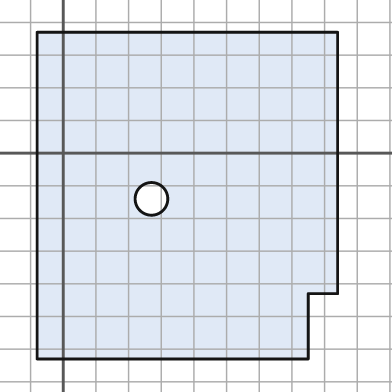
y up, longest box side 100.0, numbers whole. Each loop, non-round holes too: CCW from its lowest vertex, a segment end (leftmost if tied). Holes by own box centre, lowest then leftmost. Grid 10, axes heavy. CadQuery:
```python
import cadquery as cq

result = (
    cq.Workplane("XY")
    .moveTo(-8.0, -63.0)
    .lineTo(75.0, -63.0)
    .lineTo(75.0, -43.0)
    .lineTo(84.0, -43.0)
    .lineTo(84.0, 37.0)
    .lineTo(-8.0, 37.0)
    .close()
    .moveTo(27.0, -14.0)
    .circle(5.0)
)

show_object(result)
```